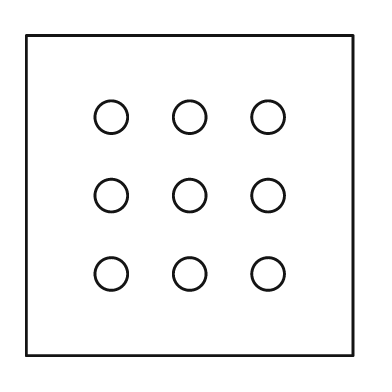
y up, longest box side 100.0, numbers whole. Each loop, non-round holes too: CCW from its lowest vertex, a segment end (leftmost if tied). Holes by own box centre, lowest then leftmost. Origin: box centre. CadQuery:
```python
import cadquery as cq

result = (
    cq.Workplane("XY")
    .moveTo(-50.0, -49.0)
    .lineTo(50.0, -49.0)
    .lineTo(50.0, 49.0)
    .lineTo(-50.0, 49.0)
    .close()
    .moveTo(-24.0, -24.0)
    .circle(5.0)
    .moveTo(0.0, -24.0)
    .circle(5.0)
    .moveTo(24.0, -24.0)
    .circle(5.0)
    .moveTo(-24.0, 0.0)
    .circle(5.0)
    .moveTo(0.0, 0.0)
    .circle(5.0)
    .moveTo(24.0, 0.0)
    .circle(5.0)
    .moveTo(-24.0, 24.0)
    .circle(5.0)
    .moveTo(0.0, 24.0)
    .circle(5.0)
    .moveTo(24.0, 24.0)
    .circle(5.0)
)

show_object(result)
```